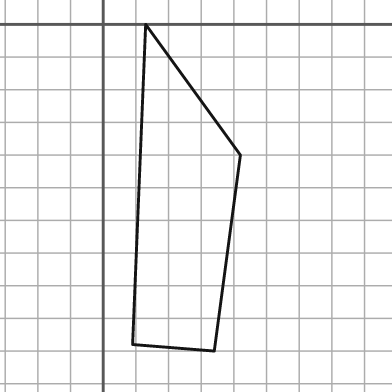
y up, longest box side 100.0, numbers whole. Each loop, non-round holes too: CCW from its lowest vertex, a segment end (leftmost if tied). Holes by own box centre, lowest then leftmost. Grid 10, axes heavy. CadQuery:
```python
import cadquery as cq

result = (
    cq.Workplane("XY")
    .moveTo(34.0, -100.0)
    .lineTo(42.0, -40.0)
    .lineTo(13.0, 0.0)
    .lineTo(9.0, -98.0)
    .close()
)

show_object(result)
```